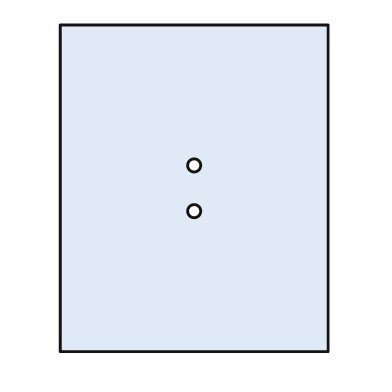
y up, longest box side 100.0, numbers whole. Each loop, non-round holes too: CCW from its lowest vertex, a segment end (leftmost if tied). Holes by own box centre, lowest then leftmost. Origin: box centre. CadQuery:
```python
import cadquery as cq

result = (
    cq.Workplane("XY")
    .moveTo(-41.0, -50.0)
    .lineTo(41.0, -50.0)
    .lineTo(41.0, 50.0)
    .lineTo(-41.0, 50.0)
    .close()
    .moveTo(0.0, -7.0)
    .circle(2.0)
    .moveTo(0.0, 7.0)
    .circle(2.0)
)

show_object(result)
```